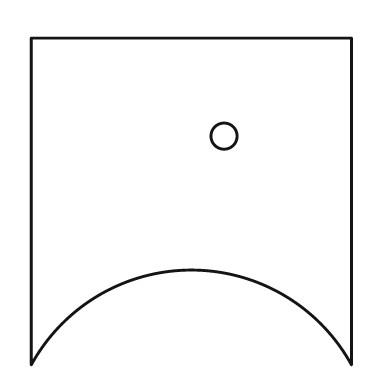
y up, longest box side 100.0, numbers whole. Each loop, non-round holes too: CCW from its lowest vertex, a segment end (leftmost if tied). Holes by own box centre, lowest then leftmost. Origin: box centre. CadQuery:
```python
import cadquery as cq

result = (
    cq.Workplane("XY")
    .moveTo(-49.0, -50.0)
    .threePointArc((0.0, -21.0), (49.0, -50.0))
    .lineTo(49.0, 50.0)
    .lineTo(-49.0, 50.0)
    .close()
    .moveTo(10.0, 20.0)
    .circle(4.0)
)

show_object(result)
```